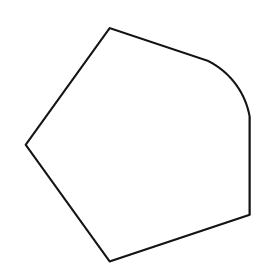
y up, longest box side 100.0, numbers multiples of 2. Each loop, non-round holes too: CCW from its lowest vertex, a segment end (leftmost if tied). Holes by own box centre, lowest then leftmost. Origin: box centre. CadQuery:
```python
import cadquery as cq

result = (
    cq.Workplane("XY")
    .moveTo(-12.0, -50.0)
    .lineTo(48.0, -30.0)
    .lineTo(48.0, 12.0)
    .threePointArc((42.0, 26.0), (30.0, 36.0))
    .lineTo(-12.0, 50.0)
    .lineTo(-48.0, 0.0)
    .close()
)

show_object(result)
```